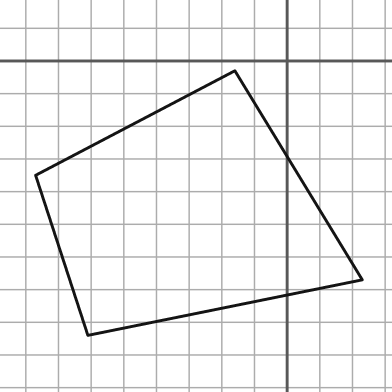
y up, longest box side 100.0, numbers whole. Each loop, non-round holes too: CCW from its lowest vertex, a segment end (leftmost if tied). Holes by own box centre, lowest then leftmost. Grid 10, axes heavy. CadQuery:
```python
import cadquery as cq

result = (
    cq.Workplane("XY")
    .moveTo(-61.0, -84.0)
    .lineTo(23.0, -67.0)
    .lineTo(-16.0, -3.0)
    .lineTo(-77.0, -35.0)
    .close()
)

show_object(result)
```